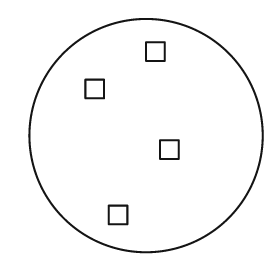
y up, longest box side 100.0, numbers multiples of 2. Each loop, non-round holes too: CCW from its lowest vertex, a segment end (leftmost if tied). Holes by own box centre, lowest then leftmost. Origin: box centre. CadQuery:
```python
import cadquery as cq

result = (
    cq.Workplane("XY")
    .moveTo(0.0, 0.0)
    .circle(50.0)
    .moveTo(-16.0, -38.0)
    .lineTo(-8.0, -38.0)
    .lineTo(-8.0, -30.0)
    .lineTo(-16.0, -30.0)
    .close()
    .moveTo(6.0, -10.0)
    .lineTo(14.0, -10.0)
    .lineTo(14.0, -2.0)
    .lineTo(6.0, -2.0)
    .close()
    .moveTo(-26.0, 16.0)
    .lineTo(-18.0, 16.0)
    .lineTo(-18.0, 24.0)
    .lineTo(-26.0, 24.0)
    .close()
    .moveTo(0.0, 32.0)
    .lineTo(8.0, 32.0)
    .lineTo(8.0, 40.0)
    .lineTo(0.0, 40.0)
    .close()
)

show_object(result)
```